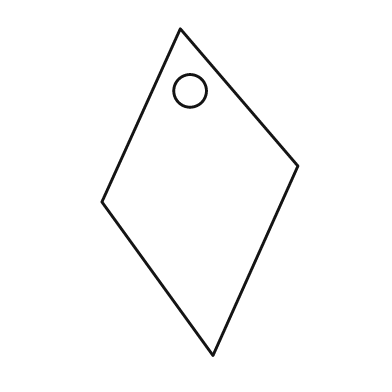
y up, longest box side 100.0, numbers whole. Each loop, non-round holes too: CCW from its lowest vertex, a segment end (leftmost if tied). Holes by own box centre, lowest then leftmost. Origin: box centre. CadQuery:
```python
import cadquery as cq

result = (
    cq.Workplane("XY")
    .moveTo(4.0, -50.0)
    .lineTo(30.0, 8.0)
    .lineTo(-6.0, 50.0)
    .lineTo(-30.0, -3.0)
    .close()
    .moveTo(-3.0, 31.0)
    .circle(5.0)
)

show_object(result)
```